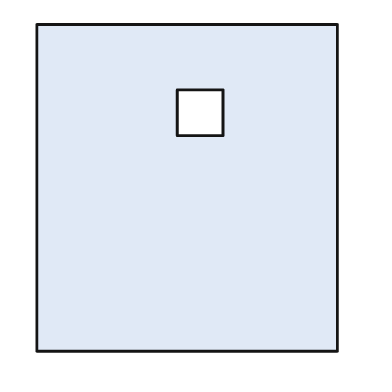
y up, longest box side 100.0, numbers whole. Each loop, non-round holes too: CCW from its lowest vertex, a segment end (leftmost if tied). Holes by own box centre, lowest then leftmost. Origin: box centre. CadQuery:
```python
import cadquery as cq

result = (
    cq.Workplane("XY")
    .moveTo(-46.0, -50.0)
    .lineTo(46.0, -50.0)
    .lineTo(46.0, 50.0)
    .lineTo(-46.0, 50.0)
    .close()
    .moveTo(-3.0, 16.0)
    .lineTo(11.0, 16.0)
    .lineTo(11.0, 30.0)
    .lineTo(-3.0, 30.0)
    .close()
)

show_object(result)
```